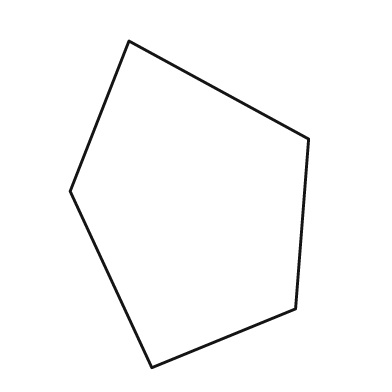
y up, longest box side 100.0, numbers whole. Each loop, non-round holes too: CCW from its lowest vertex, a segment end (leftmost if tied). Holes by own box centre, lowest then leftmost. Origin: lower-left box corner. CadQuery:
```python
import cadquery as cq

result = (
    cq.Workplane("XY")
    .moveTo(25.0, 0.0)
    .lineTo(69.0, 18.0)
    .lineTo(73.0, 70.0)
    .lineTo(18.0, 100.0)
    .lineTo(0.0, 54.0)
    .close()
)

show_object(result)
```